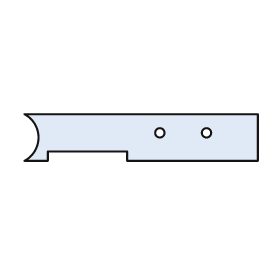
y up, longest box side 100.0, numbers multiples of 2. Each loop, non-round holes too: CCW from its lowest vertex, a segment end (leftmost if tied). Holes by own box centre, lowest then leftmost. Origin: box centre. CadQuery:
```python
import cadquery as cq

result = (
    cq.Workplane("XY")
    .moveTo(-50.0, -10.0)
    .lineTo(-40.0, -10.0)
    .lineTo(-40.0, -6.0)
    .lineTo(-6.0, -6.0)
    .lineTo(-6.0, -10.0)
    .lineTo(50.0, -10.0)
    .lineTo(50.0, 10.0)
    .lineTo(-50.0, 10.0)
    .threePointArc((-44.0, 0.0), (-50.0, -10.0))
    .close()
    .moveTo(8.0, 2.0)
    .circle(2.0)
    .moveTo(28.0, 2.0)
    .circle(2.0)
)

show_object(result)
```